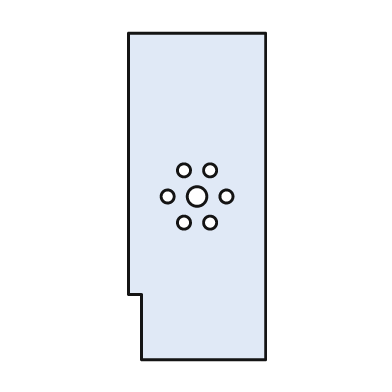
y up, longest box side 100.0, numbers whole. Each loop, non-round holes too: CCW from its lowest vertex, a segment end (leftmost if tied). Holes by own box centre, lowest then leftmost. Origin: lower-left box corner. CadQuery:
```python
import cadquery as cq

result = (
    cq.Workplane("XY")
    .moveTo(4.0, 0.0)
    .lineTo(42.0, 0.0)
    .lineTo(42.0, 100.0)
    .lineTo(0.0, 100.0)
    .lineTo(0.0, 20.0)
    .lineTo(4.0, 20.0)
    .close()
    .moveTo(17.0, 42.0)
    .circle(2.0)
    .moveTo(25.0, 42.0)
    .circle(2.0)
    .moveTo(12.0, 50.0)
    .circle(2.0)
    .moveTo(21.0, 50.0)
    .circle(3.0)
    .moveTo(30.0, 50.0)
    .circle(2.0)
    .moveTo(17.0, 58.0)
    .circle(2.0)
    .moveTo(25.0, 58.0)
    .circle(2.0)
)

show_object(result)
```